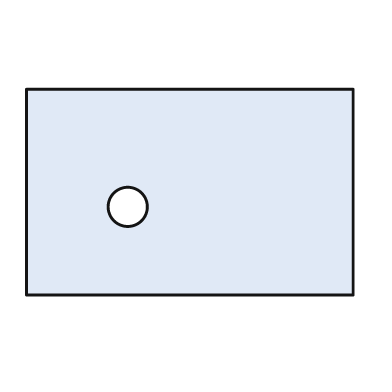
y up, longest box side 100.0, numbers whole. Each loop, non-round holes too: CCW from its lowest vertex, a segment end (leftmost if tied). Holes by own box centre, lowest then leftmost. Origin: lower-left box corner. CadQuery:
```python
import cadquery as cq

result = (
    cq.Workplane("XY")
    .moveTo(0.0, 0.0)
    .lineTo(100.0, 0.0)
    .lineTo(100.0, 63.0)
    .lineTo(0.0, 63.0)
    .close()
    .moveTo(31.0, 27.0)
    .circle(6.0)
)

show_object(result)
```